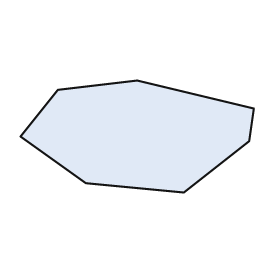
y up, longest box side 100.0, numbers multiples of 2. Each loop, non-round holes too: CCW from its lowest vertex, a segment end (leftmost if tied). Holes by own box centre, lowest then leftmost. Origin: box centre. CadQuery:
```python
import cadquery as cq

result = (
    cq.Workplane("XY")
    .moveTo(20.0, -24.0)
    .lineTo(48.0, -2.0)
    .lineTo(50.0, 12.0)
    .lineTo(0.0, 24.0)
    .lineTo(-34.0, 20.0)
    .lineTo(-50.0, 0.0)
    .lineTo(-22.0, -20.0)
    .close()
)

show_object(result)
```